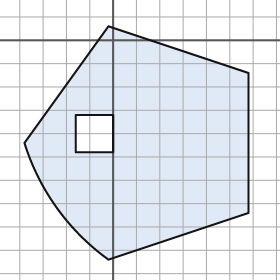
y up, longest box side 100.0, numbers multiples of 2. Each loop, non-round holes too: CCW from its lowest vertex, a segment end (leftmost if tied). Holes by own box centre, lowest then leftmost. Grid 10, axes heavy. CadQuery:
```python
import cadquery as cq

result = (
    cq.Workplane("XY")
    .moveTo(-2.0, -94.0)
    .lineTo(58.0, -74.0)
    .lineTo(58.0, -14.0)
    .lineTo(-2.0, 6.0)
    .lineTo(-38.0, -44.0)
    .threePointArc((-24.0, -72.0), (-2.0, -94.0))
    .close()
    .moveTo(-16.0, -48.0)
    .lineTo(0.0, -48.0)
    .lineTo(0.0, -32.0)
    .lineTo(-16.0, -32.0)
    .close()
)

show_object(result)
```